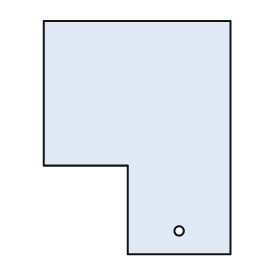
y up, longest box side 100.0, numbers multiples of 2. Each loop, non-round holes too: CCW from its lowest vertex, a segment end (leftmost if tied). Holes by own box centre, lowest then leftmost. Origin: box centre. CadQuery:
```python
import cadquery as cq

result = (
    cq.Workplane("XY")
    .moveTo(-4.0, -50.0)
    .lineTo(40.0, -50.0)
    .lineTo(40.0, 50.0)
    .lineTo(-40.0, 50.0)
    .lineTo(-40.0, -12.0)
    .lineTo(-4.0, -12.0)
    .close()
    .moveTo(18.0, -40.0)
    .circle(2.0)
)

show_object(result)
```